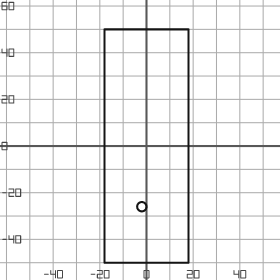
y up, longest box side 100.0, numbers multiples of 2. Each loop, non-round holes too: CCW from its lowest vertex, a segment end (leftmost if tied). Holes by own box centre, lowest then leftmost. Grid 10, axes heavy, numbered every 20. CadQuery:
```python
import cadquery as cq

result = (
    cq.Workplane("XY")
    .moveTo(-18.0, -50.0)
    .lineTo(18.0, -50.0)
    .lineTo(18.0, 50.0)
    .lineTo(-18.0, 50.0)
    .close()
    .moveTo(-2.0, -26.0)
    .circle(2.0)
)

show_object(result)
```